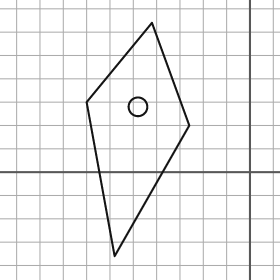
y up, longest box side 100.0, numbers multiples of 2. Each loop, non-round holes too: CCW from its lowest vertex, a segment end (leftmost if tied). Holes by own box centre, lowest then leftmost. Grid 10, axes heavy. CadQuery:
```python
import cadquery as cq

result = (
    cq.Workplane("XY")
    .moveTo(-58.0, -36.0)
    .lineTo(-26.0, 20.0)
    .lineTo(-42.0, 64.0)
    .lineTo(-70.0, 30.0)
    .close()
    .moveTo(-48.0, 28.0)
    .circle(4.0)
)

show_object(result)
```